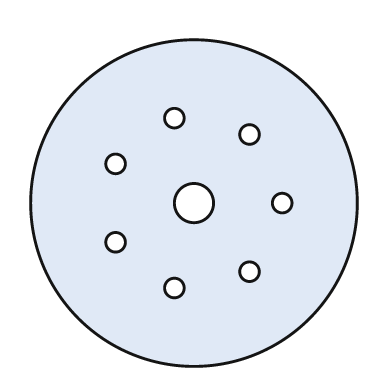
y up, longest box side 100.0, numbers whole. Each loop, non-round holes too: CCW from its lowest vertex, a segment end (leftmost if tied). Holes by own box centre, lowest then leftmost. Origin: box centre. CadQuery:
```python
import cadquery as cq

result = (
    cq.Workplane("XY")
    .moveTo(0.0, 0.0)
    .circle(50.0)
    .moveTo(-6.0, -26.0)
    .circle(3.0)
    .moveTo(17.0, -21.0)
    .circle(3.0)
    .moveTo(-24.0, -12.0)
    .circle(3.0)
    .moveTo(0.0, 0.0)
    .circle(6.0)
    .moveTo(27.0, 0.0)
    .circle(3.0)
    .moveTo(-24.0, 12.0)
    .circle(3.0)
    .moveTo(17.0, 21.0)
    .circle(3.0)
    .moveTo(-6.0, 26.0)
    .circle(3.0)
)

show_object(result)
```